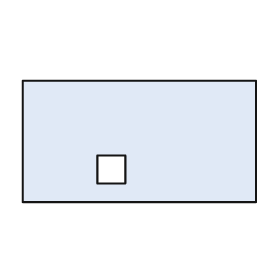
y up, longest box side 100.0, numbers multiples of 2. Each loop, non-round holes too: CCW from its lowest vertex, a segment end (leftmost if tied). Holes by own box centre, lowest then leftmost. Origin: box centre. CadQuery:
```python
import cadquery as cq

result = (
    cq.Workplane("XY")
    .moveTo(-50.0, -26.0)
    .lineTo(50.0, -26.0)
    .lineTo(50.0, 26.0)
    .lineTo(-50.0, 26.0)
    .close()
    .moveTo(-18.0, -18.0)
    .lineTo(-6.0, -18.0)
    .lineTo(-6.0, -6.0)
    .lineTo(-18.0, -6.0)
    .close()
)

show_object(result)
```